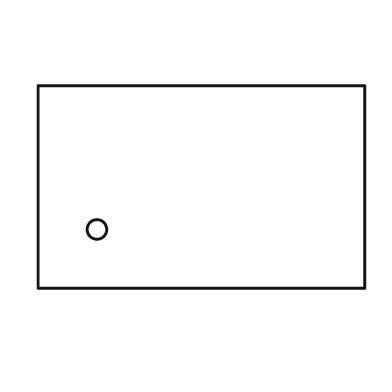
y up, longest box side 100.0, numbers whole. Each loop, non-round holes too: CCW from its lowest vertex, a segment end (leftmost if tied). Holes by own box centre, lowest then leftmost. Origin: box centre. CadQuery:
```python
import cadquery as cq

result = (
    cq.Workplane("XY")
    .moveTo(-50.0, -31.0)
    .lineTo(50.0, -31.0)
    .lineTo(50.0, 31.0)
    .lineTo(-50.0, 31.0)
    .close()
    .moveTo(-32.0, -13.0)
    .circle(3.0)
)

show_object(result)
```